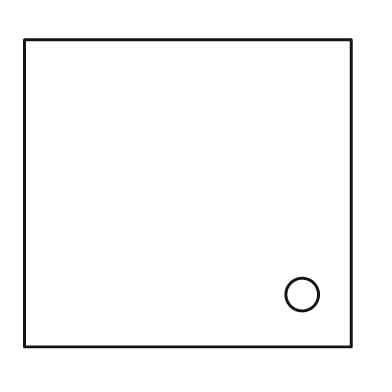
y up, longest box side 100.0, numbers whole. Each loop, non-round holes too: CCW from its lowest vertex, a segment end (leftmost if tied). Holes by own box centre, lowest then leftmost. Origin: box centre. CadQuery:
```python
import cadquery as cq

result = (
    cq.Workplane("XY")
    .moveTo(-50.0, -47.0)
    .lineTo(50.0, -47.0)
    .lineTo(50.0, 47.0)
    .lineTo(-50.0, 47.0)
    .close()
    .moveTo(35.0, -31.0)
    .circle(5.0)
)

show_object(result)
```